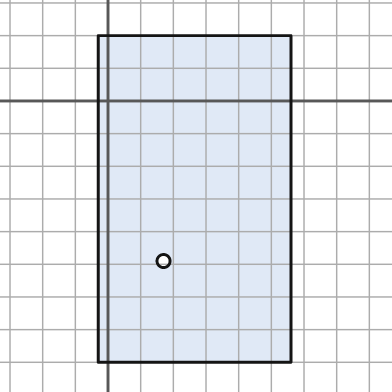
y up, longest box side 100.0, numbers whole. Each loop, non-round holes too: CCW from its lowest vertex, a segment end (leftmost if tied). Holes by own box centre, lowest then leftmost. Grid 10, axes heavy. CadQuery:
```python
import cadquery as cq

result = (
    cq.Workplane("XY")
    .moveTo(-3.0, -80.0)
    .lineTo(56.0, -80.0)
    .lineTo(56.0, 20.0)
    .lineTo(-3.0, 20.0)
    .close()
    .moveTo(17.0, -49.0)
    .circle(2.0)
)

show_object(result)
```